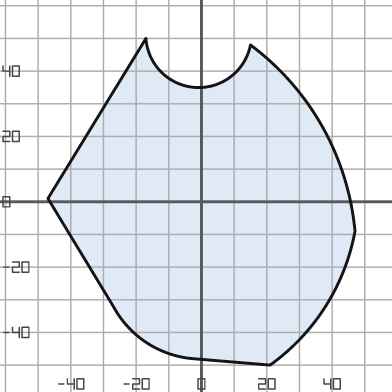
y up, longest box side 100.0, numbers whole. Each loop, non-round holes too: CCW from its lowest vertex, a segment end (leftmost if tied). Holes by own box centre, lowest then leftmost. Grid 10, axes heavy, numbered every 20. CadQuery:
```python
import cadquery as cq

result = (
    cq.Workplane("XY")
    .moveTo(21.0, -50.0)
    .threePointArc((38.0, -32.0), (47.0, -9.0))
    .threePointArc((37.0, 23.0), (15.0, 48.0))
    .threePointArc((-2.0, 35.0), (-17.0, 50.0))
    .lineTo(-47.0, 1.0)
    .lineTo(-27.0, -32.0)
    .threePointArc((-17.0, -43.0), (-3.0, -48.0))
    .close()
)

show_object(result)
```